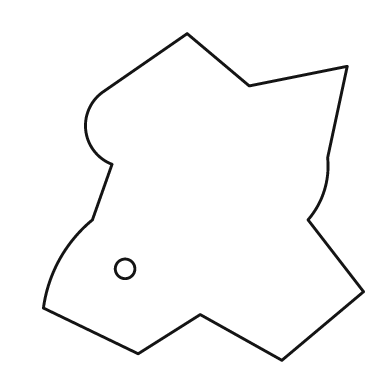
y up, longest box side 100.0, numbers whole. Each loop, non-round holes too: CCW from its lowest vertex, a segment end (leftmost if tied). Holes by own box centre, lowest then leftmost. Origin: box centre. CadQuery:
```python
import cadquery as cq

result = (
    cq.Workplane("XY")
    .moveTo(24.0, -50.0)
    .lineTo(49.0, -29.0)
    .lineTo(32.0, -7.0)
    .threePointArc((37.0, 2.0), (38.0, 12.0))
    .lineTo(44.0, 40.0)
    .lineTo(14.0, 34.0)
    .lineTo(-5.0, 50.0)
    .lineTo(-31.0, 32.0)
    .threePointArc((-36.0, 20.0), (-28.0, 10.0))
    .lineTo(-34.0, -7.0)
    .threePointArc((-44.0, -19.0), (-49.0, -34.0))
    .lineTo(-20.0, -48.0)
    .lineTo(-1.0, -36.0)
    .close()
    .moveTo(-24.0, -22.0)
    .circle(3.0)
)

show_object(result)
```